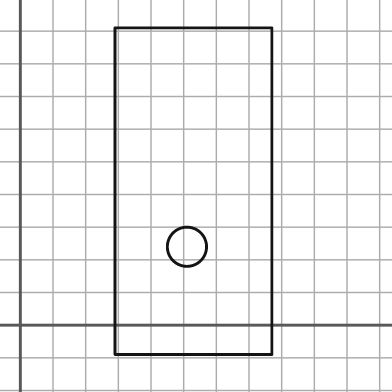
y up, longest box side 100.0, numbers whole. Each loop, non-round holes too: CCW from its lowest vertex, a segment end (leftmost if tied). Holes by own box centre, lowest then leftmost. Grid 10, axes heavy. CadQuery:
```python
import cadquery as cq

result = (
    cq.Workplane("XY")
    .moveTo(29.0, -9.0)
    .lineTo(77.0, -9.0)
    .lineTo(77.0, 91.0)
    .lineTo(29.0, 91.0)
    .close()
    .moveTo(51.0, 24.0)
    .circle(6.0)
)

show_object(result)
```